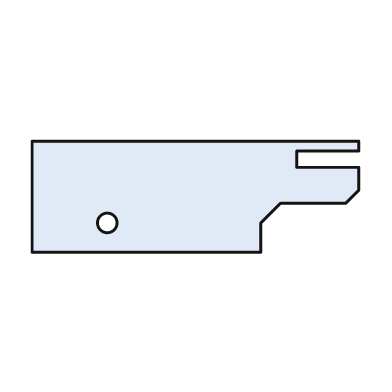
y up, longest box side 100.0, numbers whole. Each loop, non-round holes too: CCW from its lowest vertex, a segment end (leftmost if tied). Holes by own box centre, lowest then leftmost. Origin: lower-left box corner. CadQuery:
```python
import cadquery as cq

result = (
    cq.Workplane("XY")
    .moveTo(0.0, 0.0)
    .lineTo(70.0, 0.0)
    .lineTo(70.0, 9.0)
    .lineTo(76.0, 15.0)
    .lineTo(96.0, 15.0)
    .lineTo(100.0, 19.0)
    .lineTo(100.0, 26.0)
    .lineTo(81.0, 26.0)
    .lineTo(81.0, 31.0)
    .lineTo(100.0, 31.0)
    .lineTo(100.0, 34.0)
    .lineTo(0.0, 34.0)
    .close()
    .moveTo(23.0, 9.0)
    .circle(3.0)
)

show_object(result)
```